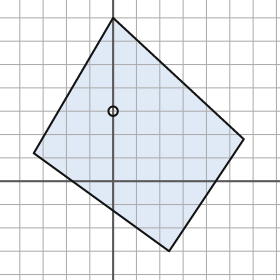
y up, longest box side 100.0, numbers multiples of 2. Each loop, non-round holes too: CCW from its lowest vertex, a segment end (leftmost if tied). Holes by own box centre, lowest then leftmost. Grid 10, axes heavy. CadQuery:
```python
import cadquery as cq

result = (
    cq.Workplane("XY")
    .moveTo(24.0, -30.0)
    .lineTo(56.0, 18.0)
    .lineTo(0.0, 70.0)
    .lineTo(-34.0, 12.0)
    .close()
    .moveTo(0.0, 30.0)
    .circle(2.0)
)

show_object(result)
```